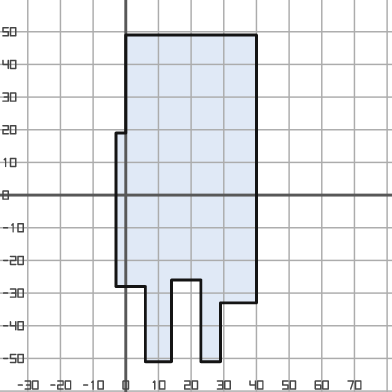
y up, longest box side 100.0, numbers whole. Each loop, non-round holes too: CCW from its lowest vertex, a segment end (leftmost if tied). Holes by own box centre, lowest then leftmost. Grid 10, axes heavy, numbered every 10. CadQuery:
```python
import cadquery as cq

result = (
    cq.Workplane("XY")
    .moveTo(6.0, -51.0)
    .lineTo(14.0, -51.0)
    .lineTo(14.0, -26.0)
    .lineTo(23.0, -26.0)
    .lineTo(23.0, -51.0)
    .lineTo(29.0, -51.0)
    .lineTo(29.0, -33.0)
    .lineTo(40.0, -33.0)
    .lineTo(40.0, 49.0)
    .lineTo(0.0, 49.0)
    .lineTo(0.0, 19.0)
    .lineTo(-3.0, 19.0)
    .lineTo(-3.0, -28.0)
    .lineTo(6.0, -28.0)
    .close()
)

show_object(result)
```